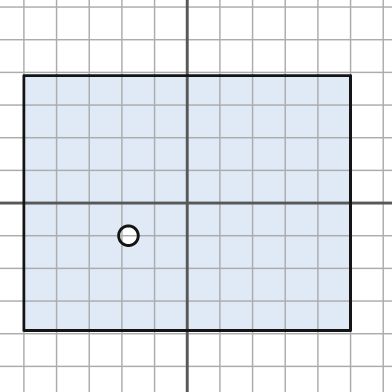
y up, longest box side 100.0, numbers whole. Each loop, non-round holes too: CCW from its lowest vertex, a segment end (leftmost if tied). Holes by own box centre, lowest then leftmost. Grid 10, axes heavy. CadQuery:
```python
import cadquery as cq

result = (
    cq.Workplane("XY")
    .moveTo(-50.0, -39.0)
    .lineTo(50.0, -39.0)
    .lineTo(50.0, 39.0)
    .lineTo(-50.0, 39.0)
    .close()
    .moveTo(-18.0, -10.0)
    .circle(3.0)
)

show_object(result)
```